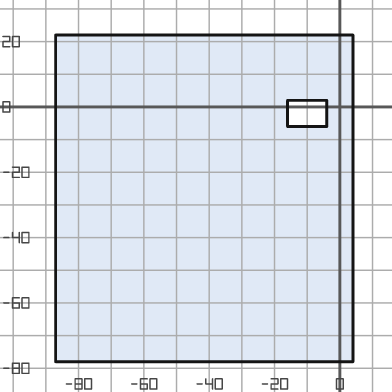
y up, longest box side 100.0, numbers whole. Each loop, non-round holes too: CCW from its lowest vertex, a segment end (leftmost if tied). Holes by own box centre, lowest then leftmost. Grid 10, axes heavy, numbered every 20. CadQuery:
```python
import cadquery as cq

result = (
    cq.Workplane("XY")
    .moveTo(-87.0, -78.0)
    .lineTo(4.0, -78.0)
    .lineTo(4.0, 22.0)
    .lineTo(-87.0, 22.0)
    .close()
    .moveTo(-16.0, -6.0)
    .lineTo(-4.0, -6.0)
    .lineTo(-4.0, 2.0)
    .lineTo(-16.0, 2.0)
    .close()
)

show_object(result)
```